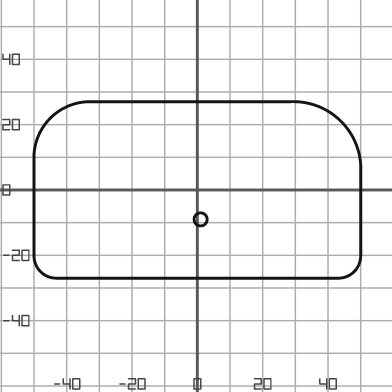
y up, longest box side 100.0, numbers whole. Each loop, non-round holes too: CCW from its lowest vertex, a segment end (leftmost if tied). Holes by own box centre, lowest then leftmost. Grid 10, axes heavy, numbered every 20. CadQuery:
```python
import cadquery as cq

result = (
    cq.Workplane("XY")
    .moveTo(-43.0, -27.0)
    .lineTo(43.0, -27.0)
    .threePointArc((48.0, -25.0), (50.0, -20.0))
    .lineTo(50.0, 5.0)
    .threePointArc((44.0, 21.0), (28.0, 27.0))
    .lineTo(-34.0, 27.0)
    .threePointArc((-45.0, 22.0), (-50.0, 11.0))
    .lineTo(-50.0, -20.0)
    .threePointArc((-48.0, -25.0), (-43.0, -27.0))
    .close()
    .moveTo(1.0, -9.0)
    .circle(2.0)
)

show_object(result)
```